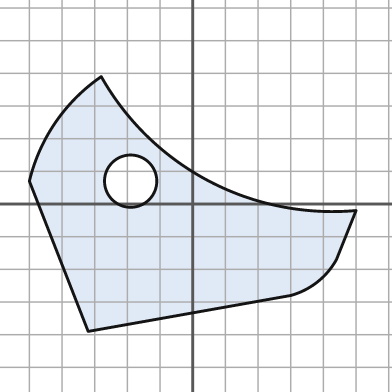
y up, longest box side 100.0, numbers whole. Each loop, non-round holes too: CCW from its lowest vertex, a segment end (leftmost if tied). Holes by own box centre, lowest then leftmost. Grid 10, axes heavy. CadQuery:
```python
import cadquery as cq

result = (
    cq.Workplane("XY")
    .moveTo(-32.0, -39.0)
    .lineTo(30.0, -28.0)
    .threePointArc((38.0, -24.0), (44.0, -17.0))
    .lineTo(50.0, -2.0)
    .threePointArc((5.0, 7.0), (-28.0, 39.0))
    .threePointArc((-42.0, 25.0), (-50.0, 7.0))
    .close()
    .moveTo(-19.0, 7.0)
    .circle(8.0)
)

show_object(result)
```